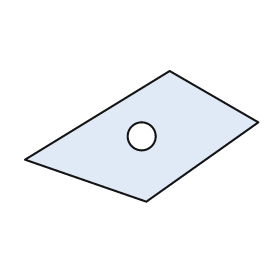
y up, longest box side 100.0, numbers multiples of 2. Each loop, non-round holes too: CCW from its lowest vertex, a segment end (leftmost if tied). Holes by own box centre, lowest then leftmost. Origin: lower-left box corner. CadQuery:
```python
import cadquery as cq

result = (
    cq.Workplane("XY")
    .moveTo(52.0, 0.0)
    .lineTo(100.0, 34.0)
    .lineTo(62.0, 56.0)
    .lineTo(0.0, 18.0)
    .close()
    .moveTo(50.0, 28.0)
    .circle(6.0)
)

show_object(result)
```